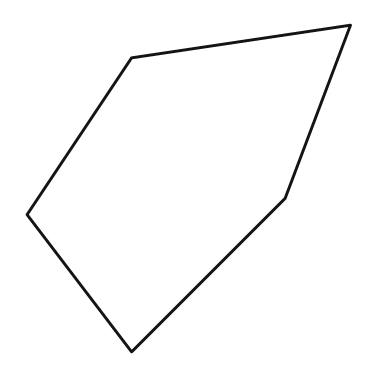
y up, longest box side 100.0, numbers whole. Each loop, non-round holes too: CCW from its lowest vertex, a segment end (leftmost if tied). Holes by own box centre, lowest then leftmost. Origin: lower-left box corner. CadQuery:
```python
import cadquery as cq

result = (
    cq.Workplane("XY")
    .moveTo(32.0, 0.0)
    .lineTo(79.0, 47.0)
    .lineTo(99.0, 100.0)
    .lineTo(32.0, 90.0)
    .lineTo(0.0, 42.0)
    .close()
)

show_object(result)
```